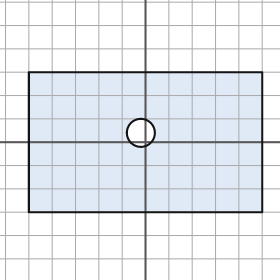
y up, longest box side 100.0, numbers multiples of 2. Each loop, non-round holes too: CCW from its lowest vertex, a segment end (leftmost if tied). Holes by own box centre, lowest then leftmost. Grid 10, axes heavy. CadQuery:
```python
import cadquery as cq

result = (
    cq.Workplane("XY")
    .moveTo(-50.0, -30.0)
    .lineTo(50.0, -30.0)
    .lineTo(50.0, 30.0)
    .lineTo(-50.0, 30.0)
    .close()
    .moveTo(-2.0, 4.0)
    .circle(6.0)
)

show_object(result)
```